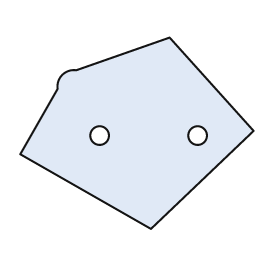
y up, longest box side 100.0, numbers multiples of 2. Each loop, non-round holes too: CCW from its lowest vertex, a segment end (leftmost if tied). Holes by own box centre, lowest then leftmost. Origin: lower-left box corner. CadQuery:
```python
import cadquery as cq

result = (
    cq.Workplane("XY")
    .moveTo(56.0, 0.0)
    .lineTo(100.0, 42.0)
    .lineTo(64.0, 82.0)
    .lineTo(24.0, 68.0)
    .threePointArc((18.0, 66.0), (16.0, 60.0))
    .lineTo(0.0, 32.0)
    .close()
    .moveTo(34.0, 40.0)
    .circle(4.0)
    .moveTo(76.0, 40.0)
    .circle(4.0)
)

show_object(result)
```